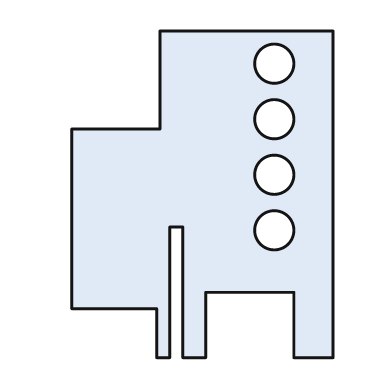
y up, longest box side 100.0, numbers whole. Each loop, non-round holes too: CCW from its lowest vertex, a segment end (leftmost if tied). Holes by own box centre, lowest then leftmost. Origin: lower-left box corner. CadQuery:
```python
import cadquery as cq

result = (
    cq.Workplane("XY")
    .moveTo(26.0, 0.0)
    .lineTo(30.0, 0.0)
    .lineTo(30.0, 40.0)
    .lineTo(34.0, 40.0)
    .lineTo(34.0, 0.0)
    .lineTo(41.0, 0.0)
    .lineTo(41.0, 20.0)
    .lineTo(68.0, 20.0)
    .lineTo(68.0, 0.0)
    .lineTo(80.0, 0.0)
    .lineTo(80.0, 100.0)
    .lineTo(27.0, 100.0)
    .lineTo(27.0, 70.0)
    .lineTo(0.0, 70.0)
    .lineTo(0.0, 15.0)
    .lineTo(26.0, 15.0)
    .close()
    .moveTo(62.0, 39.0)
    .circle(6.0)
    .moveTo(62.0, 56.0)
    .circle(6.0)
    .moveTo(62.0, 73.0)
    .circle(6.0)
    .moveTo(62.0, 90.0)
    .circle(6.0)
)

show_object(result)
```